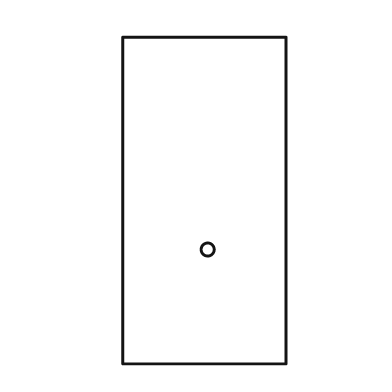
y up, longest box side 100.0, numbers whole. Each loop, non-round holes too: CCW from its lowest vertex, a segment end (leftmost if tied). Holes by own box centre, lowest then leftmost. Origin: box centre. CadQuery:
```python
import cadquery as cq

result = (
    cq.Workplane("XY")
    .moveTo(-25.0, -50.0)
    .lineTo(25.0, -50.0)
    .lineTo(25.0, 50.0)
    .lineTo(-25.0, 50.0)
    .close()
    .moveTo(1.0, -15.0)
    .circle(2.0)
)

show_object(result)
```